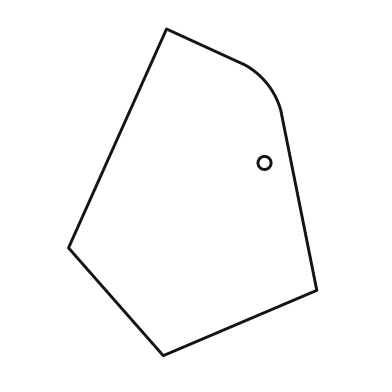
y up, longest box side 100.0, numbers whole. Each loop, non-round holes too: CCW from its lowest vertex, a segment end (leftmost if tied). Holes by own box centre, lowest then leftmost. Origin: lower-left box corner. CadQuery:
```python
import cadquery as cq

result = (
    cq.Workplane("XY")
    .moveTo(29.0, 0.0)
    .lineTo(76.0, 20.0)
    .lineTo(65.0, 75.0)
    .threePointArc((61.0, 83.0), (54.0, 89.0))
    .lineTo(30.0, 100.0)
    .lineTo(0.0, 33.0)
    .close()
    .moveTo(60.0, 59.0)
    .circle(2.0)
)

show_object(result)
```